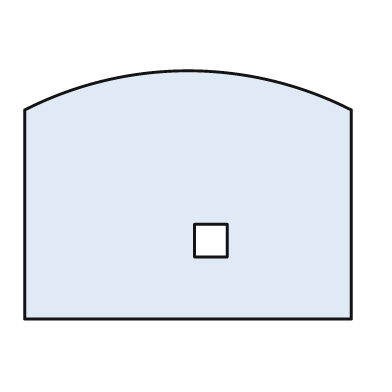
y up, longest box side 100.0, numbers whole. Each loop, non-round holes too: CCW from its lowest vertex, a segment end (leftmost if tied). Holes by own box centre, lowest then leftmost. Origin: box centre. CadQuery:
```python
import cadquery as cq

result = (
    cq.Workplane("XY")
    .moveTo(-50.0, -38.0)
    .lineTo(50.0, -38.0)
    .lineTo(50.0, 26.0)
    .threePointArc((0.0, 38.0), (-50.0, 26.0))
    .close()
    .moveTo(2.0, -19.0)
    .lineTo(12.0, -19.0)
    .lineTo(12.0, -9.0)
    .lineTo(2.0, -9.0)
    .close()
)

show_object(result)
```